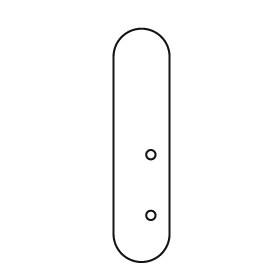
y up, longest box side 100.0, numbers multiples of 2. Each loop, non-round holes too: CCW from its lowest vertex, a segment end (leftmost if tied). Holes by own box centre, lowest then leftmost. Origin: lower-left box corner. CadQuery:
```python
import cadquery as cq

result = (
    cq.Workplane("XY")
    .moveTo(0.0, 12.0)
    .threePointArc((12.0, 0.0), (24.0, 12.0))
    .lineTo(24.0, 88.0)
    .threePointArc((12.0, 100.0), (0.0, 88.0))
    .close()
    .moveTo(16.0, 20.0)
    .circle(2.0)
    .moveTo(16.0, 46.0)
    .circle(2.0)
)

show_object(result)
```